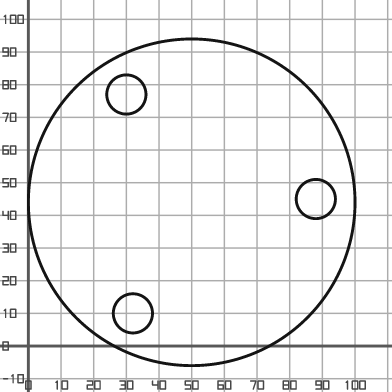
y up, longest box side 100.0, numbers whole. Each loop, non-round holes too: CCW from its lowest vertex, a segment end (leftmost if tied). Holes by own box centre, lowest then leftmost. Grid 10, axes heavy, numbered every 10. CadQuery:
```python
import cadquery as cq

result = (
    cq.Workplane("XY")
    .moveTo(50.0, 44.0)
    .circle(50.0)
    .moveTo(32.0, 10.0)
    .circle(6.0)
    .moveTo(88.0, 45.0)
    .circle(6.0)
    .moveTo(30.0, 77.0)
    .circle(6.0)
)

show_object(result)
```